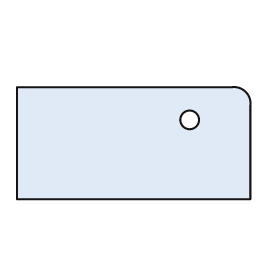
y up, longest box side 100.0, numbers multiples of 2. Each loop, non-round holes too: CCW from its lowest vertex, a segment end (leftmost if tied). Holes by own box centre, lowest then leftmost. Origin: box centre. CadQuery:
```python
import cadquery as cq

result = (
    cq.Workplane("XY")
    .moveTo(-50.0, -24.0)
    .lineTo(50.0, -24.0)
    .lineTo(50.0, 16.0)
    .threePointArc((48.0, 22.0), (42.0, 24.0))
    .lineTo(-50.0, 24.0)
    .close()
    .moveTo(24.0, 10.0)
    .circle(4.0)
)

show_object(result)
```